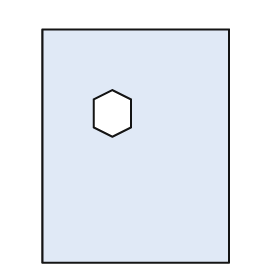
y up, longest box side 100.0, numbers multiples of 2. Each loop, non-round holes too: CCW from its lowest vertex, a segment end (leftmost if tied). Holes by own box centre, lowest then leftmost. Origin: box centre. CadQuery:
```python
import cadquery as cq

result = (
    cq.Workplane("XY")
    .moveTo(-40.0, -50.0)
    .lineTo(40.0, -50.0)
    .lineTo(40.0, 50.0)
    .lineTo(-40.0, 50.0)
    .close()
    .moveTo(-10.0, 4.0)
    .lineTo(-2.0, 8.0)
    .lineTo(-2.0, 20.0)
    .lineTo(-10.0, 24.0)
    .lineTo(-18.0, 20.0)
    .lineTo(-18.0, 8.0)
    .close()
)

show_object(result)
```